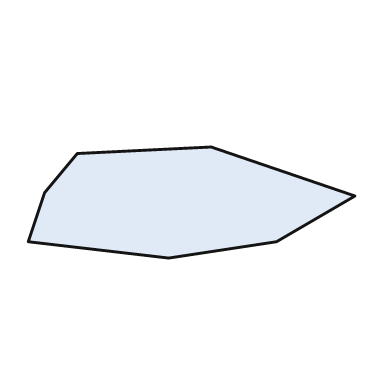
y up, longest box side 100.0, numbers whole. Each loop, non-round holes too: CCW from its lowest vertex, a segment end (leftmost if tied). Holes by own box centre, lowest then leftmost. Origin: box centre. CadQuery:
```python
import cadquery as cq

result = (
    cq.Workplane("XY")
    .moveTo(-7.0, -17.0)
    .lineTo(26.0, -12.0)
    .lineTo(50.0, 2.0)
    .lineTo(6.0, 17.0)
    .lineTo(-35.0, 15.0)
    .lineTo(-45.0, 3.0)
    .lineTo(-50.0, -12.0)
    .close()
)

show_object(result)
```